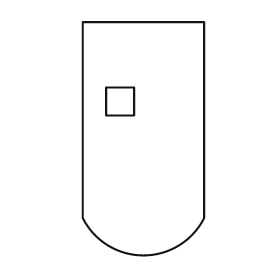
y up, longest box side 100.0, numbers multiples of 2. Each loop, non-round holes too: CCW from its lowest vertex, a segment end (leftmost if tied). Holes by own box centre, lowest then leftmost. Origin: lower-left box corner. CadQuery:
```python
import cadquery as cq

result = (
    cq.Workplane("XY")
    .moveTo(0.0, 16.0)
    .threePointArc((26.0, 0.0), (52.0, 16.0))
    .lineTo(52.0, 100.0)
    .lineTo(0.0, 100.0)
    .close()
    .moveTo(10.0, 60.0)
    .lineTo(22.0, 60.0)
    .lineTo(22.0, 72.0)
    .lineTo(10.0, 72.0)
    .close()
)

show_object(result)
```